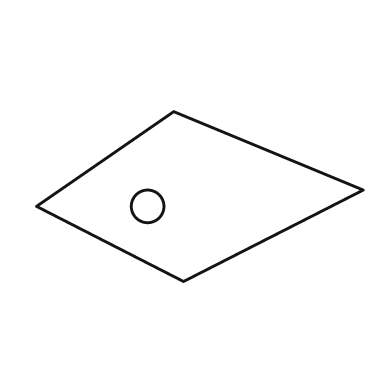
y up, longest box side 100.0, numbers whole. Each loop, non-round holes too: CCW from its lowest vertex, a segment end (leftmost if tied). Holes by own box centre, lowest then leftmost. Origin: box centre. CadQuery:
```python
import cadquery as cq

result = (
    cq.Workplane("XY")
    .moveTo(-5.0, -26.0)
    .lineTo(50.0, 2.0)
    .lineTo(-8.0, 26.0)
    .lineTo(-50.0, -3.0)
    .close()
    .moveTo(-16.0, -3.0)
    .circle(5.0)
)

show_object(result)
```